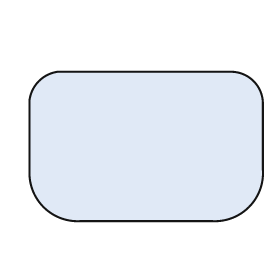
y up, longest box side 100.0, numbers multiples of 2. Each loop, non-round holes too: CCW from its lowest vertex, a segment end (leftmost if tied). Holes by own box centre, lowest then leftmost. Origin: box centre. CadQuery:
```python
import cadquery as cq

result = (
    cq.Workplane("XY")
    .moveTo(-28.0, -32.0)
    .lineTo(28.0, -32.0)
    .threePointArc((44.0, -26.0), (50.0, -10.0))
    .lineTo(50.0, 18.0)
    .threePointArc((46.0, 28.0), (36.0, 32.0))
    .lineTo(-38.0, 32.0)
    .threePointArc((-46.0, 28.0), (-50.0, 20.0))
    .lineTo(-50.0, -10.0)
    .threePointArc((-44.0, -26.0), (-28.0, -32.0))
    .close()
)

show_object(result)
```